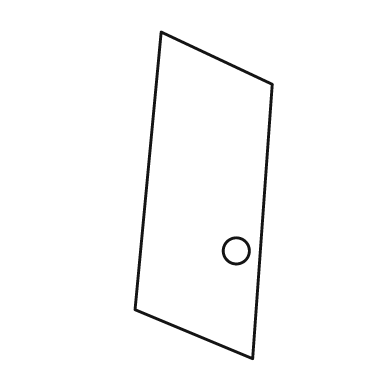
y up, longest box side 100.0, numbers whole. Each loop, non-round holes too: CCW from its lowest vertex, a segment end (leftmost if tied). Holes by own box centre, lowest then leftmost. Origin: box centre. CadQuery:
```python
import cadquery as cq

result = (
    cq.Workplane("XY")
    .moveTo(15.0, -50.0)
    .lineTo(21.0, 34.0)
    .lineTo(-13.0, 50.0)
    .lineTo(-21.0, -35.0)
    .close()
    .moveTo(10.0, -17.0)
    .circle(4.0)
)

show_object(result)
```